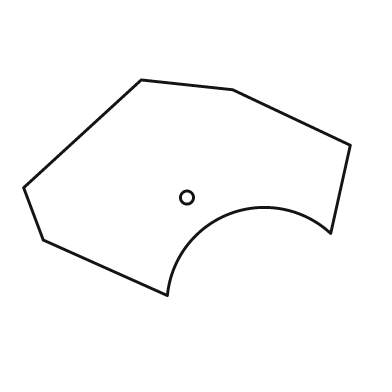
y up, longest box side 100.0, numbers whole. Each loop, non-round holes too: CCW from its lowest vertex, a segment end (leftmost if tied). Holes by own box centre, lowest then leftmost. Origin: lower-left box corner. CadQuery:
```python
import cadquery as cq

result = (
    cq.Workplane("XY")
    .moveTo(44.0, 0.0)
    .threePointArc((63.0, 25.0), (94.0, 19.0))
    .lineTo(100.0, 46.0)
    .lineTo(64.0, 63.0)
    .lineTo(36.0, 66.0)
    .lineTo(0.0, 33.0)
    .lineTo(6.0, 17.0)
    .close()
    .moveTo(50.0, 30.0)
    .circle(2.0)
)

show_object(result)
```